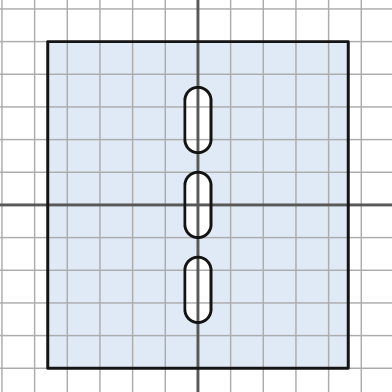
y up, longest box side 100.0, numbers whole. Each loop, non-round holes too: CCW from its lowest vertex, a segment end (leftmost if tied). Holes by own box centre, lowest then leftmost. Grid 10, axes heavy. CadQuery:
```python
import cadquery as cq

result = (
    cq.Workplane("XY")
    .moveTo(-46.0, -50.0)
    .lineTo(46.0, -50.0)
    .lineTo(46.0, 50.0)
    .lineTo(-46.0, 50.0)
    .close()
    .moveTo(-4.0, -32.0)
    .threePointArc((0.0, -36.0), (4.0, -32.0))
    .lineTo(4.0, -20.0)
    .threePointArc((0.0, -16.0), (-4.0, -20.0))
    .close()
    .moveTo(-4.0, -6.0)
    .threePointArc((0.0, -10.0), (4.0, -6.0))
    .lineTo(4.0, 6.0)
    .threePointArc((0.0, 10.0), (-4.0, 6.0))
    .close()
    .moveTo(-4.0, 20.0)
    .threePointArc((0.0, 16.0), (4.0, 20.0))
    .lineTo(4.0, 32.0)
    .threePointArc((0.0, 36.0), (-4.0, 32.0))
    .close()
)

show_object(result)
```